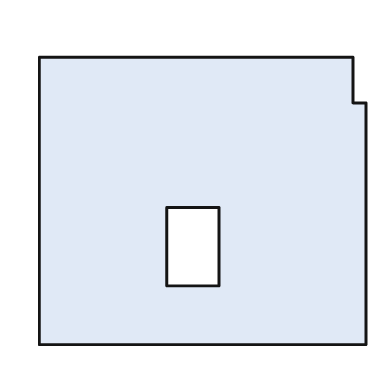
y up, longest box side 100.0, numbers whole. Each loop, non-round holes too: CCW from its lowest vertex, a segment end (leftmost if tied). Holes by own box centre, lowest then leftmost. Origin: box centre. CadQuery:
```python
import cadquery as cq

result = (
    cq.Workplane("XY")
    .moveTo(-50.0, -44.0)
    .lineTo(50.0, -44.0)
    .lineTo(50.0, 30.0)
    .lineTo(46.0, 30.0)
    .lineTo(46.0, 44.0)
    .lineTo(-50.0, 44.0)
    .close()
    .moveTo(-11.0, -26.0)
    .lineTo(5.0, -26.0)
    .lineTo(5.0, -2.0)
    .lineTo(-11.0, -2.0)
    .close()
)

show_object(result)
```